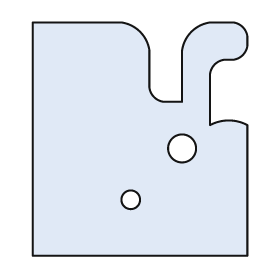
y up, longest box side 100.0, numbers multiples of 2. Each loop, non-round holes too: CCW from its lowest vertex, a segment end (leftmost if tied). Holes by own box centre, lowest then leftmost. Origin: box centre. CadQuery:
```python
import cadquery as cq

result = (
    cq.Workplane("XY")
    .moveTo(-46.0, -50.0)
    .lineTo(46.0, -50.0)
    .lineTo(46.0, 6.0)
    .threePointArc((38.0, 8.0), (30.0, 6.0))
    .lineTo(30.0, 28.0)
    .threePointArc((32.0, 32.0), (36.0, 34.0))
    .lineTo(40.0, 34.0)
    .threePointArc((44.0, 36.0), (46.0, 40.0))
    .lineTo(46.0, 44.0)
    .threePointArc((44.0, 48.0), (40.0, 50.0))
    .lineTo(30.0, 50.0)
    .threePointArc((22.0, 46.0), (18.0, 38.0))
    .lineTo(18.0, 16.0)
    .lineTo(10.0, 16.0)
    .threePointArc((6.0, 18.0), (4.0, 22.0))
    .lineTo(4.0, 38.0)
    .threePointArc((0.0, 46.0), (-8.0, 50.0))
    .lineTo(-46.0, 50.0)
    .close()
    .moveTo(-4.0, -26.0)
    .circle(4.0)
    .moveTo(18.0, -4.0)
    .circle(6.0)
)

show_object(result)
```